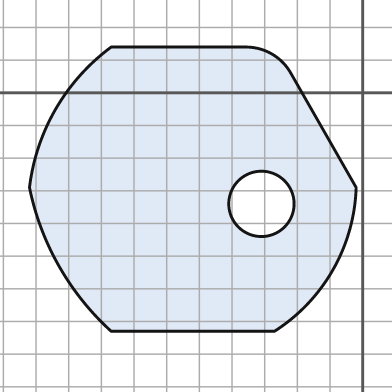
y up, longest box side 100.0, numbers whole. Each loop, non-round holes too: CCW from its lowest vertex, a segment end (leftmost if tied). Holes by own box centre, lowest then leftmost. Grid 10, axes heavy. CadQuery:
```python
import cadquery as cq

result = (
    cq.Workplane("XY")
    .moveTo(-77.0, -73.0)
    .lineTo(-27.0, -73.0)
    .threePointArc((-9.0, -54.0), (-2.0, -29.0))
    .lineTo(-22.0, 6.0)
    .threePointArc((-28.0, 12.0), (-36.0, 14.0))
    .lineTo(-77.0, 14.0)
    .threePointArc((-94.0, -5.0), (-102.0, -29.0))
    .threePointArc((-93.0, -53.0), (-77.0, -73.0))
    .close()
    .moveTo(-31.0, -34.0)
    .circle(10.0)
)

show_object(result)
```